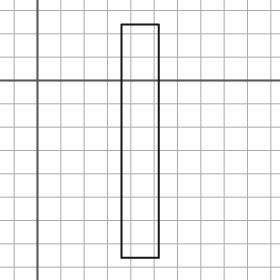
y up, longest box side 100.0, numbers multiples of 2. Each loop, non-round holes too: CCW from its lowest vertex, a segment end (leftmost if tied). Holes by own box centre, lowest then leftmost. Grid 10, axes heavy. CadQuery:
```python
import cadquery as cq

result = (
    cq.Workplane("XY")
    .moveTo(36.0, -76.0)
    .lineTo(52.0, -76.0)
    .lineTo(52.0, 24.0)
    .lineTo(36.0, 24.0)
    .close()
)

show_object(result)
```